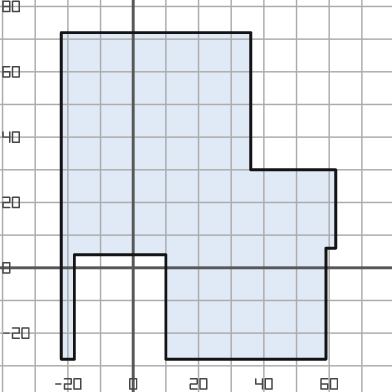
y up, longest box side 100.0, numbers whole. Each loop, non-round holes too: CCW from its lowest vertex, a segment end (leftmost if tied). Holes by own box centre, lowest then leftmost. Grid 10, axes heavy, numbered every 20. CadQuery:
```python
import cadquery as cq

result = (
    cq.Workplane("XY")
    .moveTo(-22.0, -28.0)
    .lineTo(-18.0, -28.0)
    .lineTo(-18.0, 4.0)
    .lineTo(10.0, 4.0)
    .lineTo(10.0, -28.0)
    .lineTo(59.0, -28.0)
    .lineTo(59.0, 6.0)
    .lineTo(62.0, 6.0)
    .lineTo(62.0, 30.0)
    .lineTo(36.0, 30.0)
    .lineTo(36.0, 72.0)
    .lineTo(-22.0, 72.0)
    .close()
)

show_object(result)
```